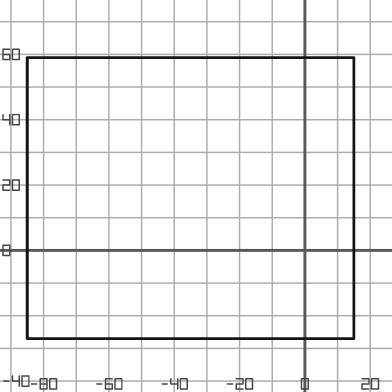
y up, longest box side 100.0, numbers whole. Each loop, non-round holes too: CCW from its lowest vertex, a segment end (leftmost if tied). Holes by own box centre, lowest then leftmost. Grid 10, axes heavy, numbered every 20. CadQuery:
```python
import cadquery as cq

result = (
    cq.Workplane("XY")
    .moveTo(-85.0, -27.0)
    .lineTo(15.0, -27.0)
    .lineTo(15.0, 59.0)
    .lineTo(-85.0, 59.0)
    .close()
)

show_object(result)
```